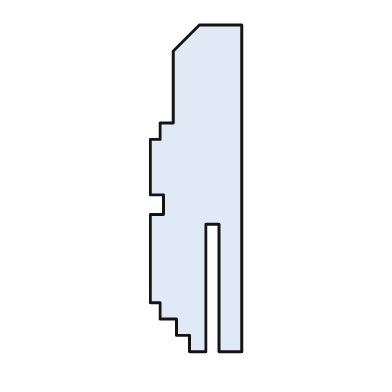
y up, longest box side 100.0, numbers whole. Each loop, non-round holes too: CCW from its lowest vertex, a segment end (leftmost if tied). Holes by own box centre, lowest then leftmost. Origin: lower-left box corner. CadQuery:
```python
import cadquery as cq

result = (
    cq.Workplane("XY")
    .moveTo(12.0, 0.0)
    .lineTo(17.0, 0.0)
    .lineTo(17.0, 39.0)
    .lineTo(21.0, 39.0)
    .lineTo(21.0, 0.0)
    .lineTo(28.0, 0.0)
    .lineTo(28.0, 100.0)
    .lineTo(15.0, 100.0)
    .lineTo(7.0, 92.0)
    .lineTo(7.0, 70.0)
    .lineTo(3.0, 70.0)
    .lineTo(3.0, 65.0)
    .lineTo(0.0, 65.0)
    .lineTo(0.0, 48.0)
    .lineTo(4.0, 48.0)
    .lineTo(4.0, 42.0)
    .lineTo(0.0, 42.0)
    .lineTo(0.0, 15.0)
    .lineTo(3.0, 15.0)
    .lineTo(3.0, 10.0)
    .lineTo(8.0, 10.0)
    .lineTo(8.0, 5.0)
    .lineTo(12.0, 5.0)
    .close()
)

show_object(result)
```